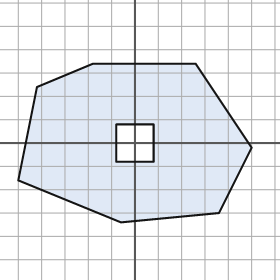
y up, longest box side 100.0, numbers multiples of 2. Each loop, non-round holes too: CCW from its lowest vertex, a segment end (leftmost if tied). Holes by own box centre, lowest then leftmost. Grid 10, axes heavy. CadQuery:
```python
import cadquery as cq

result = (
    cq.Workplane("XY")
    .moveTo(-6.0, -34.0)
    .lineTo(36.0, -30.0)
    .lineTo(50.0, -2.0)
    .lineTo(26.0, 34.0)
    .lineTo(-18.0, 34.0)
    .lineTo(-42.0, 24.0)
    .lineTo(-50.0, -16.0)
    .close()
    .moveTo(-8.0, -8.0)
    .lineTo(8.0, -8.0)
    .lineTo(8.0, 8.0)
    .lineTo(-8.0, 8.0)
    .close()
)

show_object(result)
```